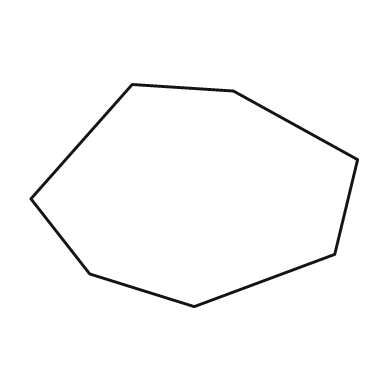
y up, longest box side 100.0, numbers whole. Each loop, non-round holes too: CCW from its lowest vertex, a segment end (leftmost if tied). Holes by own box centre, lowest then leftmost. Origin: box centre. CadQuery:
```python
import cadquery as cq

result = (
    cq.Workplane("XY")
    .moveTo(0.0, -34.0)
    .lineTo(43.0, -18.0)
    .lineTo(50.0, 11.0)
    .lineTo(12.0, 32.0)
    .lineTo(-19.0, 34.0)
    .lineTo(-50.0, -1.0)
    .lineTo(-32.0, -24.0)
    .close()
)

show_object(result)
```